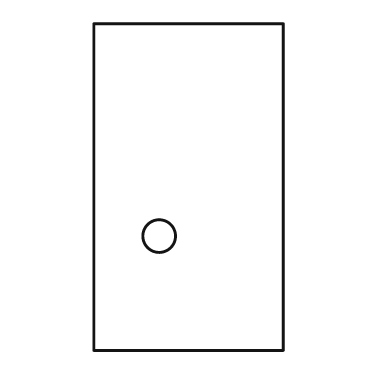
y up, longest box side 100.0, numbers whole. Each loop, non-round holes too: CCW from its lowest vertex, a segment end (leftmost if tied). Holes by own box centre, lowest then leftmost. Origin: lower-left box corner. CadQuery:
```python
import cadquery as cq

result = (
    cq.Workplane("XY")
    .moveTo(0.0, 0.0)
    .lineTo(58.0, 0.0)
    .lineTo(58.0, 100.0)
    .lineTo(0.0, 100.0)
    .close()
    .moveTo(20.0, 35.0)
    .circle(5.0)
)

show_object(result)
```